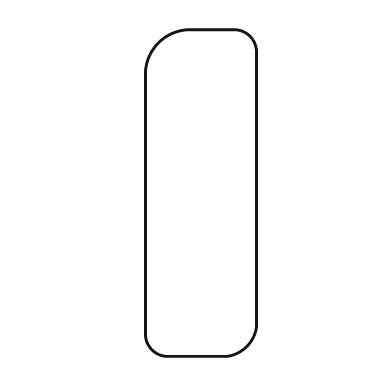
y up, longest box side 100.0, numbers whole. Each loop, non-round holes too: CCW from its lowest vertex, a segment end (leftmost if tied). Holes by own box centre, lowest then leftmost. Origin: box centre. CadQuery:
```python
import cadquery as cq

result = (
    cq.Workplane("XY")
    .moveTo(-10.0, -50.0)
    .lineTo(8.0, -50.0)
    .threePointArc((14.0, -47.0), (17.0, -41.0))
    .lineTo(17.0, 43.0)
    .threePointArc((15.0, 48.0), (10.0, 50.0))
    .lineTo(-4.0, 50.0)
    .threePointArc((-13.0, 46.0), (-17.0, 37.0))
    .lineTo(-17.0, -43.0)
    .threePointArc((-15.0, -48.0), (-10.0, -50.0))
    .close()
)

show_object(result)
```